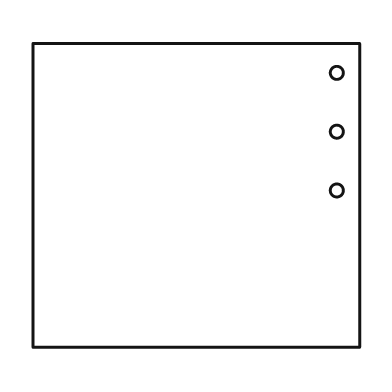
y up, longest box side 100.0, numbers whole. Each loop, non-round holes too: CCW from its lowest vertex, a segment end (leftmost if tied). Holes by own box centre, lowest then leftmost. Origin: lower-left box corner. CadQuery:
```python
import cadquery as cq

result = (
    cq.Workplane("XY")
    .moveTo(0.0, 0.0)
    .lineTo(100.0, 0.0)
    .lineTo(100.0, 93.0)
    .lineTo(0.0, 93.0)
    .close()
    .moveTo(93.0, 48.0)
    .circle(2.0)
    .moveTo(93.0, 66.0)
    .circle(2.0)
    .moveTo(93.0, 84.0)
    .circle(2.0)
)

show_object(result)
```